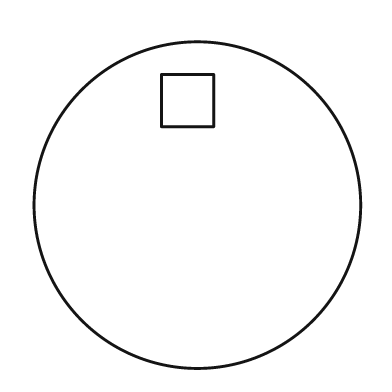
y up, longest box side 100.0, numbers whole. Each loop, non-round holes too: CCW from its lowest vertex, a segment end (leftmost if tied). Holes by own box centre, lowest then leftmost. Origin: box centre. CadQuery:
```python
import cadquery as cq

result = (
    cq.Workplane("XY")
    .moveTo(0.0, 0.0)
    .circle(50.0)
    .moveTo(-11.0, 24.0)
    .lineTo(5.0, 24.0)
    .lineTo(5.0, 40.0)
    .lineTo(-11.0, 40.0)
    .close()
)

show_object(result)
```